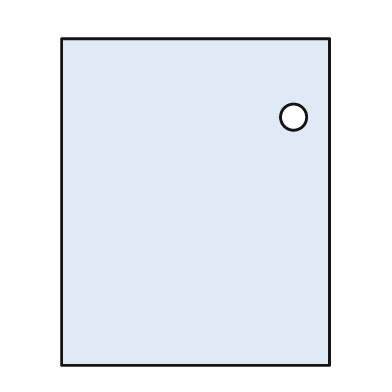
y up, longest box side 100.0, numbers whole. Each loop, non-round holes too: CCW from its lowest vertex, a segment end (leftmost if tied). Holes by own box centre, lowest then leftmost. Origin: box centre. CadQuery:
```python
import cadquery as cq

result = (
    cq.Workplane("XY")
    .moveTo(-41.0, -50.0)
    .lineTo(41.0, -50.0)
    .lineTo(41.0, 50.0)
    .lineTo(-41.0, 50.0)
    .close()
    .moveTo(30.0, 26.0)
    .circle(4.0)
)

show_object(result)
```